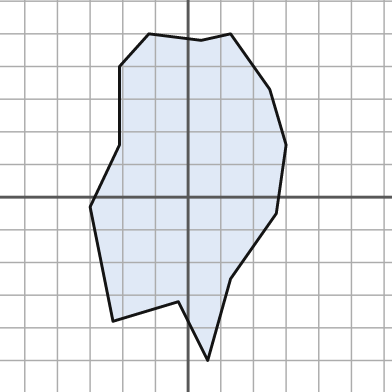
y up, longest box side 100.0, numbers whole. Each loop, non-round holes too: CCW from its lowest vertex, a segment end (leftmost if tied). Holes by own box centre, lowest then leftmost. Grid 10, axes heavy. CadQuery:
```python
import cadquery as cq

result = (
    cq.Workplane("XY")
    .moveTo(6.0, -50.0)
    .lineTo(13.0, -25.0)
    .lineTo(27.0, -5.0)
    .lineTo(30.0, 16.0)
    .lineTo(25.0, 33.0)
    .lineTo(13.0, 50.0)
    .lineTo(4.0, 48.0)
    .lineTo(-12.0, 50.0)
    .lineTo(-21.0, 40.0)
    .lineTo(-21.0, 16.0)
    .lineTo(-30.0, -3.0)
    .lineTo(-23.0, -38.0)
    .lineTo(-3.0, -32.0)
    .close()
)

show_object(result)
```